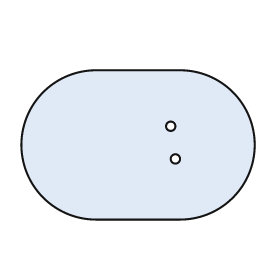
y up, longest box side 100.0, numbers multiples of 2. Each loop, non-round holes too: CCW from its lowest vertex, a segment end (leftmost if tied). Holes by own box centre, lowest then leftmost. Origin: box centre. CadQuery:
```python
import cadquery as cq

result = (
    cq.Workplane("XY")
    .moveTo(-18.0, -32.0)
    .lineTo(18.0, -32.0)
    .threePointArc((50.0, 0.0), (18.0, 32.0))
    .lineTo(-18.0, 32.0)
    .threePointArc((-50.0, 0.0), (-18.0, -32.0))
    .close()
    .moveTo(16.0, -6.0)
    .circle(2.0)
    .moveTo(14.0, 8.0)
    .circle(2.0)
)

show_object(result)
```